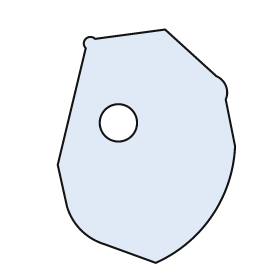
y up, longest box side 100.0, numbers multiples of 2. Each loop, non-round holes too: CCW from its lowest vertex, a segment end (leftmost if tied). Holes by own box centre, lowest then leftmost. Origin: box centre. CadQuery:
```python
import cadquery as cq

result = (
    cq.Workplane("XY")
    .moveTo(4.0, -50.0)
    .threePointArc((28.0, -30.0), (38.0, 0.0))
    .lineTo(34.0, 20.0)
    .threePointArc((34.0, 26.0), (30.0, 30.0))
    .lineTo(8.0, 50.0)
    .lineTo(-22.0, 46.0)
    .threePointArc((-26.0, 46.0), (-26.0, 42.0))
    .lineTo(-38.0, -8.0)
    .lineTo(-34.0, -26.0)
    .threePointArc((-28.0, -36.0), (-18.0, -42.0))
    .close()
    .moveTo(-12.0, 10.0)
    .circle(8.0)
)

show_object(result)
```